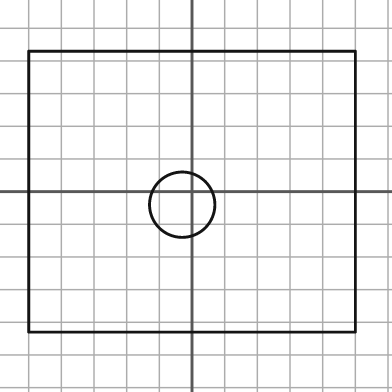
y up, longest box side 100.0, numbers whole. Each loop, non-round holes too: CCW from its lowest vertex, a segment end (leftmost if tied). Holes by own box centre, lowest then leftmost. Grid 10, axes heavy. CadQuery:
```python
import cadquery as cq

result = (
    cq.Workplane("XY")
    .moveTo(-50.0, -43.0)
    .lineTo(50.0, -43.0)
    .lineTo(50.0, 43.0)
    .lineTo(-50.0, 43.0)
    .close()
    .moveTo(-3.0, -4.0)
    .circle(10.0)
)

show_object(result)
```